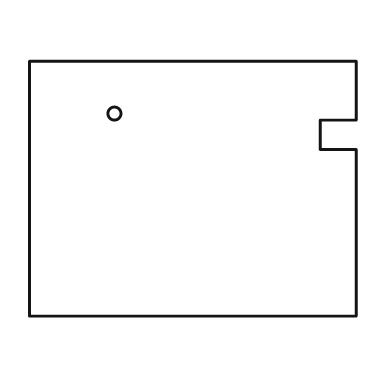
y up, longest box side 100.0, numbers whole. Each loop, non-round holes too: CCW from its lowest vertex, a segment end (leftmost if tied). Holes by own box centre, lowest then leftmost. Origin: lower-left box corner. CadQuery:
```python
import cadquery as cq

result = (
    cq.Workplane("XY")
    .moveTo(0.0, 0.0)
    .lineTo(100.0, 0.0)
    .lineTo(100.0, 51.0)
    .lineTo(89.0, 51.0)
    .lineTo(89.0, 60.0)
    .lineTo(100.0, 60.0)
    .lineTo(100.0, 78.0)
    .lineTo(0.0, 78.0)
    .close()
    .moveTo(26.0, 62.0)
    .circle(2.0)
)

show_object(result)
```